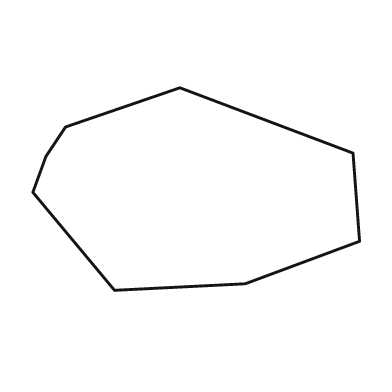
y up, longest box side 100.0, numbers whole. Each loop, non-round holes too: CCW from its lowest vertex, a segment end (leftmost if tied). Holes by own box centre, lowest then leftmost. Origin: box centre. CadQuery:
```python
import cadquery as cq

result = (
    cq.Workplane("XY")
    .moveTo(-25.0, -31.0)
    .lineTo(15.0, -29.0)
    .lineTo(50.0, -16.0)
    .lineTo(48.0, 11.0)
    .lineTo(-5.0, 31.0)
    .lineTo(-40.0, 19.0)
    .lineTo(-46.0, 10.0)
    .lineTo(-50.0, -1.0)
    .close()
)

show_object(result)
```